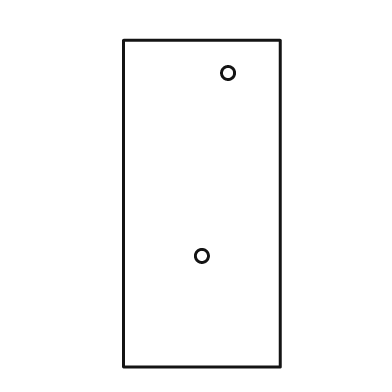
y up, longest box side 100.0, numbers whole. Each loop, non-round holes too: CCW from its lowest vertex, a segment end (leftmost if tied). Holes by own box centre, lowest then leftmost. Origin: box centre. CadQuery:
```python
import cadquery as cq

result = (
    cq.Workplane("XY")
    .moveTo(-24.0, -50.0)
    .lineTo(24.0, -50.0)
    .lineTo(24.0, 50.0)
    .lineTo(-24.0, 50.0)
    .close()
    .moveTo(0.0, -16.0)
    .circle(2.0)
    .moveTo(8.0, 40.0)
    .circle(2.0)
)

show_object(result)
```